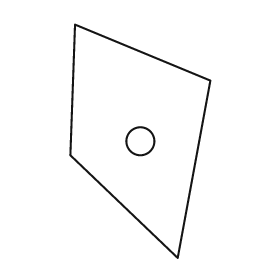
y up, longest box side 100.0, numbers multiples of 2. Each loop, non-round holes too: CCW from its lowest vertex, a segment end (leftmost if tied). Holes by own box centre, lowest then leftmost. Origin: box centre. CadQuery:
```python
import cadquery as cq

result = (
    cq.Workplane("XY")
    .moveTo(16.0, -50.0)
    .lineTo(30.0, 26.0)
    .lineTo(-28.0, 50.0)
    .lineTo(-30.0, -6.0)
    .close()
    .moveTo(0.0, 0.0)
    .circle(6.0)
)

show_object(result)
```